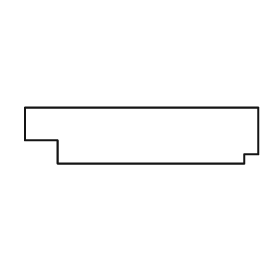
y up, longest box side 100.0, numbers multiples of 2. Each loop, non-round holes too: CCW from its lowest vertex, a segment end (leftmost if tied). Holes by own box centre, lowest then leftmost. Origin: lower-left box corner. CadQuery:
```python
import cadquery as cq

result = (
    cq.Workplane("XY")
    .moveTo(14.0, 0.0)
    .lineTo(94.0, 0.0)
    .lineTo(94.0, 4.0)
    .lineTo(100.0, 4.0)
    .lineTo(100.0, 24.0)
    .lineTo(0.0, 24.0)
    .lineTo(0.0, 10.0)
    .lineTo(14.0, 10.0)
    .close()
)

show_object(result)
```